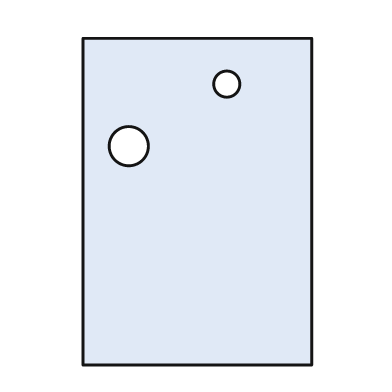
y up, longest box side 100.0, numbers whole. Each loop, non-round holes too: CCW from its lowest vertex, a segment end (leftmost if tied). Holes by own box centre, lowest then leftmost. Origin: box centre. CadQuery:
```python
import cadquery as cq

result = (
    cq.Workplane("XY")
    .moveTo(-35.0, -50.0)
    .lineTo(35.0, -50.0)
    .lineTo(35.0, 50.0)
    .lineTo(-35.0, 50.0)
    .close()
    .moveTo(-21.0, 17.0)
    .circle(6.0)
    .moveTo(9.0, 36.0)
    .circle(4.0)
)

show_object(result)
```